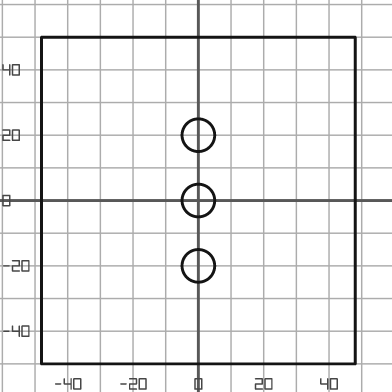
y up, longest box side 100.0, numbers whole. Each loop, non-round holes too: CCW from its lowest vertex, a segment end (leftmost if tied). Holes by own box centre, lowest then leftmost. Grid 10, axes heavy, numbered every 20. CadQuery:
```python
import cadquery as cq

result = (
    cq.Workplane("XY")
    .moveTo(-48.0, -50.0)
    .lineTo(48.0, -50.0)
    .lineTo(48.0, 50.0)
    .lineTo(-48.0, 50.0)
    .close()
    .moveTo(0.0, -20.0)
    .circle(5.0)
    .moveTo(0.0, 0.0)
    .circle(5.0)
    .moveTo(0.0, 20.0)
    .circle(5.0)
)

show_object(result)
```